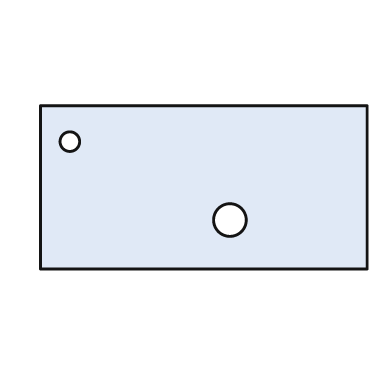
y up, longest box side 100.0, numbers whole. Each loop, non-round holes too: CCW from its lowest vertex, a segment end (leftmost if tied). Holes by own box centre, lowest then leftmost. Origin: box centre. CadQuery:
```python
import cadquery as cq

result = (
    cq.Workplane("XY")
    .moveTo(-50.0, -25.0)
    .lineTo(50.0, -25.0)
    .lineTo(50.0, 25.0)
    .lineTo(-50.0, 25.0)
    .close()
    .moveTo(8.0, -10.0)
    .circle(5.0)
    .moveTo(-41.0, 14.0)
    .circle(3.0)
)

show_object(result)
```